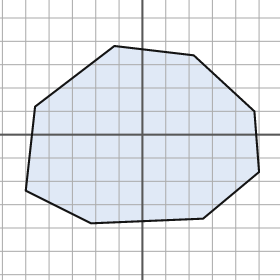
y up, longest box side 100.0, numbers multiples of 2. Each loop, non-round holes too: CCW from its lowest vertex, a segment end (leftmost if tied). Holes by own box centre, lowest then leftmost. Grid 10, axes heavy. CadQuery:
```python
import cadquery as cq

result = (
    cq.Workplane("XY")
    .moveTo(-22.0, -38.0)
    .lineTo(26.0, -36.0)
    .lineTo(50.0, -16.0)
    .lineTo(48.0, 10.0)
    .lineTo(22.0, 34.0)
    .lineTo(-12.0, 38.0)
    .lineTo(-46.0, 12.0)
    .lineTo(-50.0, -24.0)
    .close()
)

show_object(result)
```